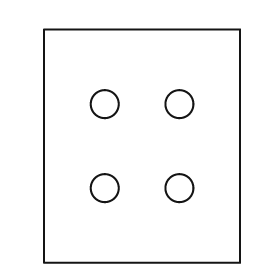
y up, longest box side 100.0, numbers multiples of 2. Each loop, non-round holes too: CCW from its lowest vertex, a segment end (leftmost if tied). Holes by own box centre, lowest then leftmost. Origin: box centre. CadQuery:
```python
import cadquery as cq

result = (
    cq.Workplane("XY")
    .moveTo(-42.0, -50.0)
    .lineTo(42.0, -50.0)
    .lineTo(42.0, 50.0)
    .lineTo(-42.0, 50.0)
    .close()
    .moveTo(-16.0, -18.0)
    .circle(6.0)
    .moveTo(16.0, -18.0)
    .circle(6.0)
    .moveTo(-16.0, 18.0)
    .circle(6.0)
    .moveTo(16.0, 18.0)
    .circle(6.0)
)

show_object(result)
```